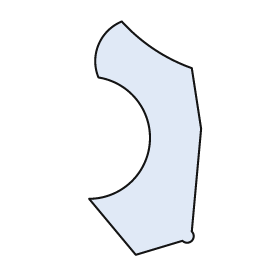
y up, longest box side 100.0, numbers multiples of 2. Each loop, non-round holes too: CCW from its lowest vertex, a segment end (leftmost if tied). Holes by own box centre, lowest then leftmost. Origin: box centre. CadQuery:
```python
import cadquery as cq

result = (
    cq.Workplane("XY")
    .moveTo(-4.0, -50.0)
    .lineTo(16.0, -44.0)
    .threePointArc((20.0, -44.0), (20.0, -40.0))
    .lineTo(24.0, 4.0)
    .lineTo(20.0, 30.0)
    .threePointArc((4.0, 38.0), (-10.0, 50.0))
    .threePointArc((-20.0, 40.0), (-20.0, 26.0))
    .threePointArc((2.0, -2.0), (-24.0, -26.0))
    .close()
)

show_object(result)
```